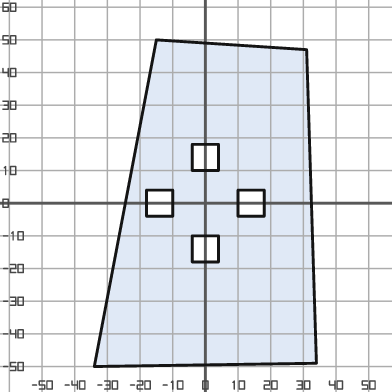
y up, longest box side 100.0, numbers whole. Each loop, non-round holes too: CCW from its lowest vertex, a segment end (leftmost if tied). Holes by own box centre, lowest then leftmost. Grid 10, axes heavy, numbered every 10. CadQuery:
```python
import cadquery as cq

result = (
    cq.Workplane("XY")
    .moveTo(-34.0, -50.0)
    .lineTo(34.0, -49.0)
    .lineTo(31.0, 47.0)
    .lineTo(-15.0, 50.0)
    .close()
    .moveTo(-4.0, -18.0)
    .lineTo(4.0, -18.0)
    .lineTo(4.0, -10.0)
    .lineTo(-4.0, -10.0)
    .close()
    .moveTo(-18.0, -4.0)
    .lineTo(-10.0, -4.0)
    .lineTo(-10.0, 4.0)
    .lineTo(-18.0, 4.0)
    .close()
    .moveTo(10.0, -4.0)
    .lineTo(18.0, -4.0)
    .lineTo(18.0, 4.0)
    .lineTo(10.0, 4.0)
    .close()
    .moveTo(-4.0, 10.0)
    .lineTo(4.0, 10.0)
    .lineTo(4.0, 18.0)
    .lineTo(-4.0, 18.0)
    .close()
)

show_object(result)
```